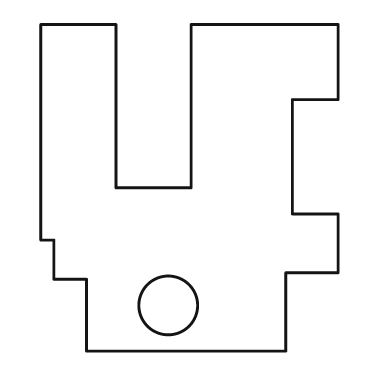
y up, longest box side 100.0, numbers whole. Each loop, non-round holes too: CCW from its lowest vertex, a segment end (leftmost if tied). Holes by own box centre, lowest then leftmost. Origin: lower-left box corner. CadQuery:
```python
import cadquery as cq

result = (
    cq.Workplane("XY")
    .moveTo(14.0, 0.0)
    .lineTo(75.0, 0.0)
    .lineTo(75.0, 24.0)
    .lineTo(91.0, 24.0)
    .lineTo(91.0, 42.0)
    .lineTo(77.0, 42.0)
    .lineTo(77.0, 77.0)
    .lineTo(91.0, 77.0)
    .lineTo(91.0, 100.0)
    .lineTo(46.0, 100.0)
    .lineTo(46.0, 50.0)
    .lineTo(23.0, 50.0)
    .lineTo(23.0, 100.0)
    .lineTo(0.0, 100.0)
    .lineTo(0.0, 34.0)
    .lineTo(4.0, 34.0)
    .lineTo(4.0, 22.0)
    .lineTo(14.0, 22.0)
    .close()
    .moveTo(39.0, 14.0)
    .circle(9.0)
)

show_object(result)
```